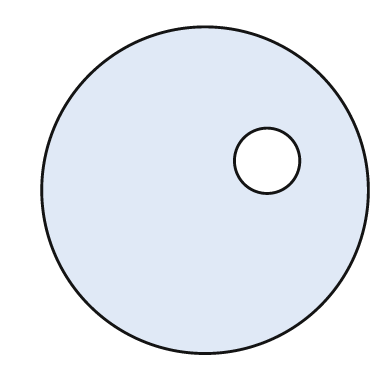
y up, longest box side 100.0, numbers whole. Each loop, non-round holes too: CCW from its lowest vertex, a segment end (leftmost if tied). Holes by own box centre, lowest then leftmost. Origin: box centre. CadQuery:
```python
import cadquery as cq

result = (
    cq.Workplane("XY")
    .moveTo(0.0, 0.0)
    .circle(50.0)
    .moveTo(19.0, 9.0)
    .circle(10.0)
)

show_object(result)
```